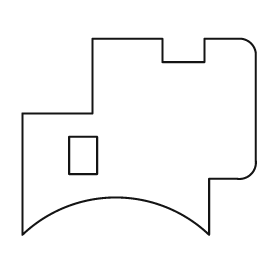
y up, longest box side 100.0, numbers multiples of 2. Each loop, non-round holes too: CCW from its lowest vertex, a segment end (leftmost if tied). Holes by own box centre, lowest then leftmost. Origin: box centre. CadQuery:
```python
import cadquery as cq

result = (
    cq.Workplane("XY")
    .moveTo(-50.0, -42.0)
    .threePointArc((-10.0, -26.0), (30.0, -42.0))
    .lineTo(30.0, -18.0)
    .lineTo(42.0, -18.0)
    .threePointArc((48.0, -16.0), (50.0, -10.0))
    .lineTo(50.0, 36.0)
    .threePointArc((48.0, 40.0), (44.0, 42.0))
    .lineTo(28.0, 42.0)
    .lineTo(28.0, 32.0)
    .lineTo(10.0, 32.0)
    .lineTo(10.0, 42.0)
    .lineTo(-20.0, 42.0)
    .lineTo(-20.0, 10.0)
    .lineTo(-50.0, 10.0)
    .close()
    .moveTo(-30.0, -16.0)
    .lineTo(-18.0, -16.0)
    .lineTo(-18.0, 0.0)
    .lineTo(-30.0, 0.0)
    .close()
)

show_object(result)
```